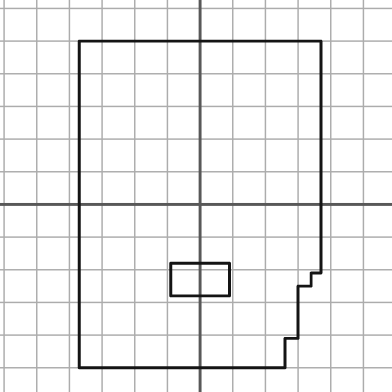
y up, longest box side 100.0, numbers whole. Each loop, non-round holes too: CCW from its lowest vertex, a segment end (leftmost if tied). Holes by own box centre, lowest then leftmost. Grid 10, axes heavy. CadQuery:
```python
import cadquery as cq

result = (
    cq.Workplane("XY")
    .moveTo(-37.0, -50.0)
    .lineTo(26.0, -50.0)
    .lineTo(26.0, -41.0)
    .lineTo(30.0, -41.0)
    .lineTo(30.0, -25.0)
    .lineTo(34.0, -25.0)
    .lineTo(34.0, -21.0)
    .lineTo(37.0, -21.0)
    .lineTo(37.0, 50.0)
    .lineTo(-37.0, 50.0)
    .close()
    .moveTo(-9.0, -28.0)
    .lineTo(9.0, -28.0)
    .lineTo(9.0, -18.0)
    .lineTo(-9.0, -18.0)
    .close()
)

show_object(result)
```